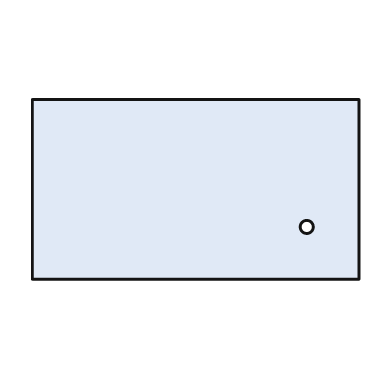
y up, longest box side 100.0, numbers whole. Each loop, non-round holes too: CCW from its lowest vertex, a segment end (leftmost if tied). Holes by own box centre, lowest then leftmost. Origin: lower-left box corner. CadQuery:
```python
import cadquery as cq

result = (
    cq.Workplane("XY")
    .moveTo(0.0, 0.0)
    .lineTo(100.0, 0.0)
    .lineTo(100.0, 55.0)
    .lineTo(0.0, 55.0)
    .close()
    .moveTo(84.0, 16.0)
    .circle(2.0)
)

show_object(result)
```